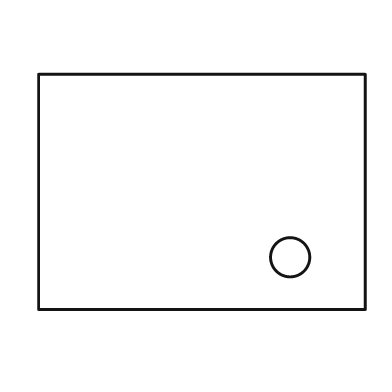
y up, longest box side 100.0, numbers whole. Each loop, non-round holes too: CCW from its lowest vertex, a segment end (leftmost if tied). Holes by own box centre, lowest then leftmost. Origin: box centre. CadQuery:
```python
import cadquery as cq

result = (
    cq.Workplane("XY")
    .moveTo(-50.0, -36.0)
    .lineTo(50.0, -36.0)
    .lineTo(50.0, 36.0)
    .lineTo(-50.0, 36.0)
    .close()
    .moveTo(27.0, -20.0)
    .circle(6.0)
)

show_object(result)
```